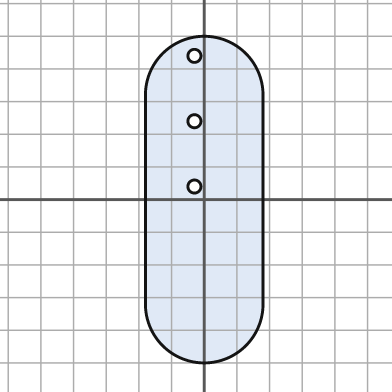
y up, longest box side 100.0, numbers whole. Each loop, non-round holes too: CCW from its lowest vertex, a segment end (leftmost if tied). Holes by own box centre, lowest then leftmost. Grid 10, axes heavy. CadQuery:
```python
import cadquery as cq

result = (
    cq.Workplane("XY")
    .moveTo(-18.0, -32.0)
    .threePointArc((0.0, -50.0), (18.0, -32.0))
    .lineTo(18.0, 32.0)
    .threePointArc((0.0, 50.0), (-18.0, 32.0))
    .close()
    .moveTo(-3.0, 4.0)
    .circle(2.0)
    .moveTo(-3.0, 24.0)
    .circle(2.0)
    .moveTo(-3.0, 44.0)
    .circle(2.0)
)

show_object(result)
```